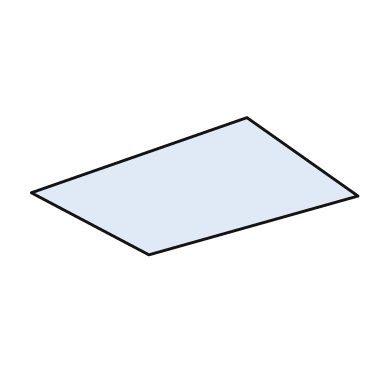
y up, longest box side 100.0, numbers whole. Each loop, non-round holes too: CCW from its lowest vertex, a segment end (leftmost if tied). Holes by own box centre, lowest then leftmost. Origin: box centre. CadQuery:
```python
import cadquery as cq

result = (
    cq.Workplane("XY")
    .moveTo(-14.0, -21.0)
    .lineTo(50.0, -3.0)
    .lineTo(16.0, 21.0)
    .lineTo(-50.0, -2.0)
    .close()
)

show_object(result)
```